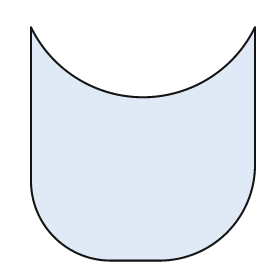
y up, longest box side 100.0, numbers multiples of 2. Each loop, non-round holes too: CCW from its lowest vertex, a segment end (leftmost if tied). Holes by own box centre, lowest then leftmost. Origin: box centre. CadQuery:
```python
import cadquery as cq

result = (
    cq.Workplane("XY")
    .moveTo(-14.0, -50.0)
    .lineTo(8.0, -50.0)
    .threePointArc((36.0, -38.0), (48.0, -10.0))
    .lineTo(48.0, 50.0)
    .threePointArc((0.0, 20.0), (-48.0, 50.0))
    .lineTo(-48.0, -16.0)
    .threePointArc((-38.0, -40.0), (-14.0, -50.0))
    .close()
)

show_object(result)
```